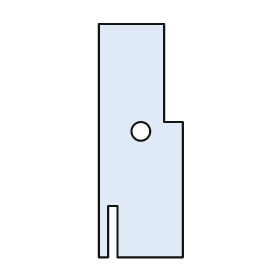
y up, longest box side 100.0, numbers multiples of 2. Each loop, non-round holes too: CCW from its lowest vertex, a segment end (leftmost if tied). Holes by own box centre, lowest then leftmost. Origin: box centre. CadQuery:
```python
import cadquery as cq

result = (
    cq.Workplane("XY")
    .moveTo(-18.0, -50.0)
    .lineTo(-14.0, -50.0)
    .lineTo(-14.0, -28.0)
    .lineTo(-10.0, -28.0)
    .lineTo(-10.0, -50.0)
    .lineTo(18.0, -50.0)
    .lineTo(18.0, 8.0)
    .lineTo(10.0, 8.0)
    .lineTo(10.0, 50.0)
    .lineTo(-18.0, 50.0)
    .close()
    .moveTo(0.0, 4.0)
    .circle(4.0)
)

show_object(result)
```